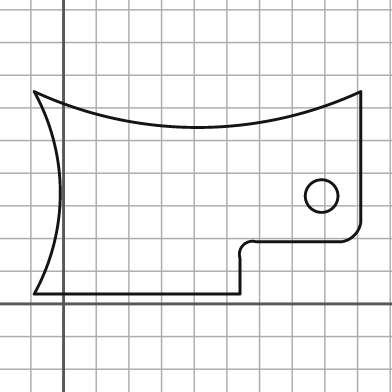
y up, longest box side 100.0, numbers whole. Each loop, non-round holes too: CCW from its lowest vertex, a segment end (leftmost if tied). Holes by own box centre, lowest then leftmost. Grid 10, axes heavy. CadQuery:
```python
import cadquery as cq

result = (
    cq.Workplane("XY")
    .moveTo(-9.0, 3.0)
    .lineTo(54.0, 3.0)
    .lineTo(54.0, 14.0)
    .threePointArc((55.0, 18.0), (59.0, 19.0))
    .lineTo(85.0, 19.0)
    .threePointArc((89.0, 21.0), (91.0, 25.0))
    .lineTo(91.0, 65.0)
    .threePointArc((41.0, 54.0), (-9.0, 65.0))
    .threePointArc((-1.0, 34.0), (-9.0, 3.0))
    .close()
    .moveTo(79.0, 33.0)
    .circle(5.0)
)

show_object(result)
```